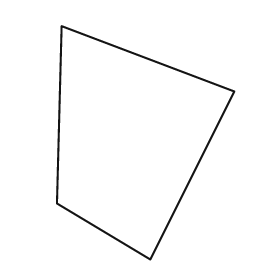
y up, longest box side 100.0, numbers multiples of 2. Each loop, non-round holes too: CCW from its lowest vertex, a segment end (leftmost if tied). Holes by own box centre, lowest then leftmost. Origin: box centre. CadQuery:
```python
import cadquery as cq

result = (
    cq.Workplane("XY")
    .moveTo(2.0, -50.0)
    .lineTo(38.0, 22.0)
    .lineTo(-36.0, 50.0)
    .lineTo(-38.0, -26.0)
    .close()
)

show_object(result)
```